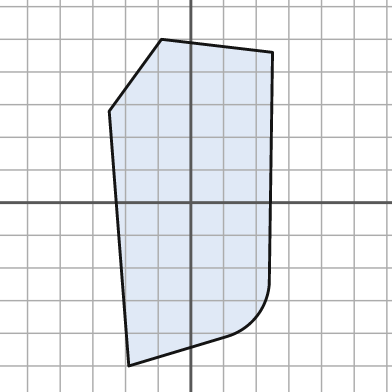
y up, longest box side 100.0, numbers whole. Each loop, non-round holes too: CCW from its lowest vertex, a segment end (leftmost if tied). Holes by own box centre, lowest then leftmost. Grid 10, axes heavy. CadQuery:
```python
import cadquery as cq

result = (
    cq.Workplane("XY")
    .moveTo(-19.0, -50.0)
    .lineTo(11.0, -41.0)
    .threePointArc((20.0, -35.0), (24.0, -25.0))
    .lineTo(25.0, 46.0)
    .lineTo(-9.0, 50.0)
    .lineTo(-25.0, 28.0)
    .close()
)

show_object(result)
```